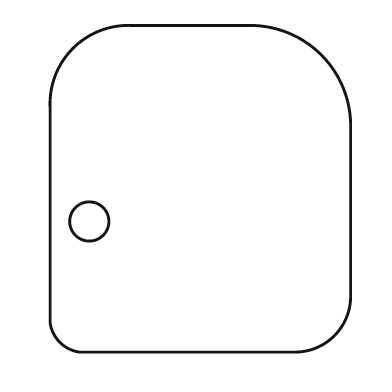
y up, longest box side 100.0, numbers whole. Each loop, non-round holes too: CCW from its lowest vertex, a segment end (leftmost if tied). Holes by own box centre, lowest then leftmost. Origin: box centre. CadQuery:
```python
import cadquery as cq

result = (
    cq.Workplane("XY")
    .moveTo(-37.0, -50.0)
    .lineTo(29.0, -50.0)
    .threePointArc((41.0, -45.0), (46.0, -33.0))
    .lineTo(46.0, 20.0)
    .threePointArc((37.0, 41.0), (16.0, 50.0))
    .lineTo(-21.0, 50.0)
    .threePointArc((-39.0, 43.0), (-46.0, 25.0))
    .lineTo(-46.0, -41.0)
    .threePointArc((-43.0, -47.0), (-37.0, -50.0))
    .close()
    .moveTo(-34.0, -10.0)
    .circle(6.0)
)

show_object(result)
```